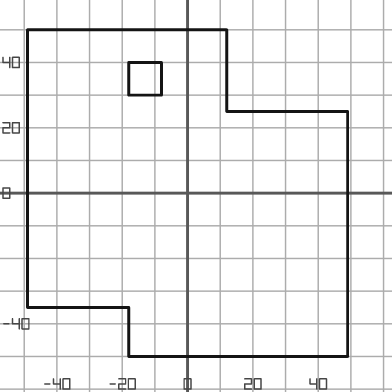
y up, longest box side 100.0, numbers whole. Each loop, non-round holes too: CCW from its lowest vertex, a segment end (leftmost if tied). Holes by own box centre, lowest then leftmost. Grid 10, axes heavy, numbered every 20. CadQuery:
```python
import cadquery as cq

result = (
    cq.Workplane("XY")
    .moveTo(-18.0, -50.0)
    .lineTo(49.0, -50.0)
    .lineTo(49.0, 25.0)
    .lineTo(12.0, 25.0)
    .lineTo(12.0, 50.0)
    .lineTo(-49.0, 50.0)
    .lineTo(-49.0, -35.0)
    .lineTo(-18.0, -35.0)
    .close()
    .moveTo(-18.0, 30.0)
    .lineTo(-8.0, 30.0)
    .lineTo(-8.0, 40.0)
    .lineTo(-18.0, 40.0)
    .close()
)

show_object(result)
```